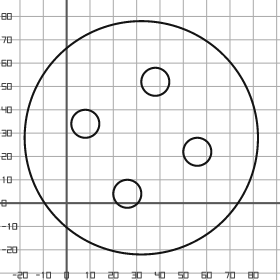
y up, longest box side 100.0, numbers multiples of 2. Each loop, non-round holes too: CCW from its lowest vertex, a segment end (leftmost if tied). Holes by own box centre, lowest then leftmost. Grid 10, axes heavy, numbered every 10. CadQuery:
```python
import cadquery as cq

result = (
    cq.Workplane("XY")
    .moveTo(32.0, 28.0)
    .circle(50.0)
    .moveTo(26.0, 4.0)
    .circle(6.0)
    .moveTo(56.0, 22.0)
    .circle(6.0)
    .moveTo(8.0, 34.0)
    .circle(6.0)
    .moveTo(38.0, 52.0)
    .circle(6.0)
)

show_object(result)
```